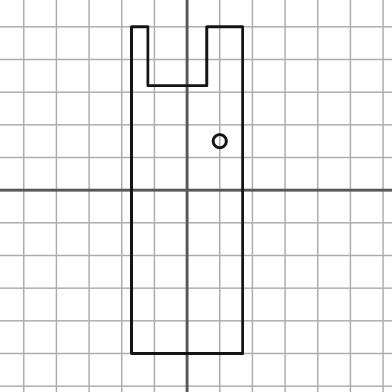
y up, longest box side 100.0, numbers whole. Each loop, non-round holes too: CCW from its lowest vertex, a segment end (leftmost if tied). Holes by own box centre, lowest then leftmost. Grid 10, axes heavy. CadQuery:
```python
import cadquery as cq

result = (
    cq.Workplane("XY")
    .moveTo(-17.0, -50.0)
    .lineTo(17.0, -50.0)
    .lineTo(17.0, 50.0)
    .lineTo(6.0, 50.0)
    .lineTo(6.0, 32.0)
    .lineTo(-12.0, 32.0)
    .lineTo(-12.0, 50.0)
    .lineTo(-17.0, 50.0)
    .close()
    .moveTo(10.0, 15.0)
    .circle(2.0)
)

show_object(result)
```